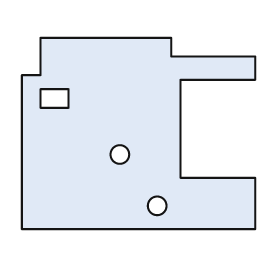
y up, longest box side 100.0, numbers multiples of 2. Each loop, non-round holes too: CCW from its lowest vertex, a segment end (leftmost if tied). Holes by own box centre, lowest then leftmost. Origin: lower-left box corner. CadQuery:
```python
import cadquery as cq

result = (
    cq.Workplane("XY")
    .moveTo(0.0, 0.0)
    .lineTo(100.0, 0.0)
    .lineTo(100.0, 22.0)
    .lineTo(68.0, 22.0)
    .lineTo(68.0, 64.0)
    .lineTo(100.0, 64.0)
    .lineTo(100.0, 74.0)
    .lineTo(64.0, 74.0)
    .lineTo(64.0, 82.0)
    .lineTo(8.0, 82.0)
    .lineTo(8.0, 66.0)
    .lineTo(0.0, 66.0)
    .close()
    .moveTo(58.0, 10.0)
    .circle(4.0)
    .moveTo(42.0, 32.0)
    .circle(4.0)
    .moveTo(8.0, 52.0)
    .lineTo(20.0, 52.0)
    .lineTo(20.0, 60.0)
    .lineTo(8.0, 60.0)
    .close()
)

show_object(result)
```